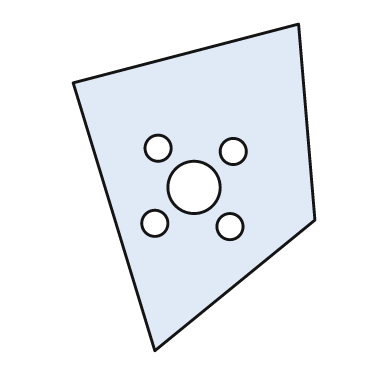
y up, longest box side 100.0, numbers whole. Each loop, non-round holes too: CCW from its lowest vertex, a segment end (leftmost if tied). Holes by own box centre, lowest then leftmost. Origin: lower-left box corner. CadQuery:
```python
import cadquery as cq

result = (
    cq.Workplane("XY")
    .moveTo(25.0, 0.0)
    .lineTo(74.0, 40.0)
    .lineTo(69.0, 100.0)
    .lineTo(0.0, 82.0)
    .close()
    .moveTo(48.0, 38.0)
    .circle(4.0)
    .moveTo(25.0, 39.0)
    .circle(4.0)
    .moveTo(37.0, 50.0)
    .circle(8.0)
    .moveTo(49.0, 61.0)
    .circle(4.0)
    .moveTo(26.0, 62.0)
    .circle(4.0)
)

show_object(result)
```